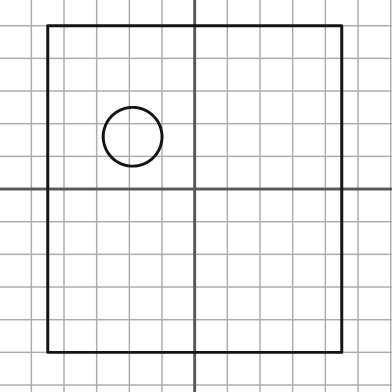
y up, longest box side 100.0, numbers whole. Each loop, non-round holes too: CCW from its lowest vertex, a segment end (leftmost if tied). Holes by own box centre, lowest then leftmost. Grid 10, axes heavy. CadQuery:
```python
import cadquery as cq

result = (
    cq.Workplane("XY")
    .moveTo(-45.0, -50.0)
    .lineTo(45.0, -50.0)
    .lineTo(45.0, 50.0)
    .lineTo(-45.0, 50.0)
    .close()
    .moveTo(-19.0, 16.0)
    .circle(9.0)
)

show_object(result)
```